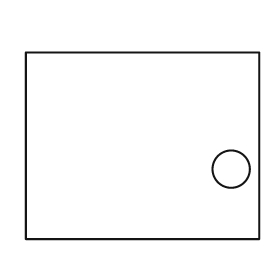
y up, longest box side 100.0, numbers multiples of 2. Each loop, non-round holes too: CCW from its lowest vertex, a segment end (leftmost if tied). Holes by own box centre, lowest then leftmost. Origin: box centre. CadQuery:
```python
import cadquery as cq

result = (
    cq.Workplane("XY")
    .moveTo(-50.0, -40.0)
    .lineTo(50.0, -40.0)
    .lineTo(50.0, 40.0)
    .lineTo(-50.0, 40.0)
    .close()
    .moveTo(38.0, -10.0)
    .circle(8.0)
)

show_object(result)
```